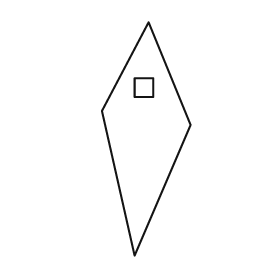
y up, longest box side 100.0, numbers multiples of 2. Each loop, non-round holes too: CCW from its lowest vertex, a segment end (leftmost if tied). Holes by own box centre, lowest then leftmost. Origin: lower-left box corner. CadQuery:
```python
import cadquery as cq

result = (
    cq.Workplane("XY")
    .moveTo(14.0, 0.0)
    .lineTo(38.0, 56.0)
    .lineTo(20.0, 100.0)
    .lineTo(0.0, 62.0)
    .close()
    .moveTo(14.0, 68.0)
    .lineTo(22.0, 68.0)
    .lineTo(22.0, 76.0)
    .lineTo(14.0, 76.0)
    .close()
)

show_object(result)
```